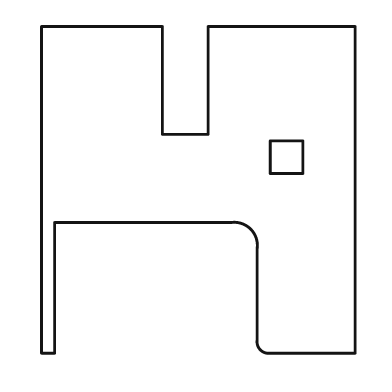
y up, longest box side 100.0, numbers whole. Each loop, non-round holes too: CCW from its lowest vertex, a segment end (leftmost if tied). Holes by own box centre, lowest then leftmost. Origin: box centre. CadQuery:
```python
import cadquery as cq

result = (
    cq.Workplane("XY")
    .moveTo(-48.0, -50.0)
    .lineTo(-44.0, -50.0)
    .lineTo(-44.0, -10.0)
    .lineTo(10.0, -10.0)
    .threePointArc((16.0, -12.0), (18.0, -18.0))
    .lineTo(18.0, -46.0)
    .threePointArc((19.0, -49.0), (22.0, -50.0))
    .lineTo(48.0, -50.0)
    .lineTo(48.0, 50.0)
    .lineTo(3.0, 50.0)
    .lineTo(3.0, 17.0)
    .lineTo(-11.0, 17.0)
    .lineTo(-11.0, 50.0)
    .lineTo(-48.0, 50.0)
    .close()
    .moveTo(22.0, 5.0)
    .lineTo(32.0, 5.0)
    .lineTo(32.0, 15.0)
    .lineTo(22.0, 15.0)
    .close()
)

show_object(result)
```